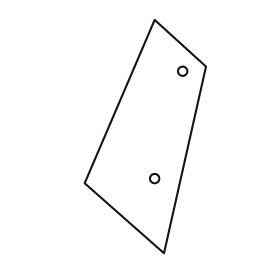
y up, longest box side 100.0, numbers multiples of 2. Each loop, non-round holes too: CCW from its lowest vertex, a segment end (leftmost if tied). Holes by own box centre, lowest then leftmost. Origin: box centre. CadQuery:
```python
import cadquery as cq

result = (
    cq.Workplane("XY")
    .moveTo(8.0, -50.0)
    .lineTo(26.0, 30.0)
    .lineTo(4.0, 50.0)
    .lineTo(-26.0, -20.0)
    .close()
    .moveTo(4.0, -18.0)
    .circle(2.0)
    .moveTo(16.0, 28.0)
    .circle(2.0)
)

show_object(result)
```